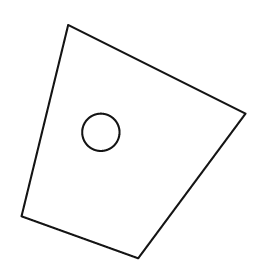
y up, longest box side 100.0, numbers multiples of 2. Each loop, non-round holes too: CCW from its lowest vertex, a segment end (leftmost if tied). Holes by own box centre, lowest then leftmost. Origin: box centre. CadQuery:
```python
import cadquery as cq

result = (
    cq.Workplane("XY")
    .moveTo(2.0, -50.0)
    .lineTo(48.0, 12.0)
    .lineTo(-28.0, 50.0)
    .lineTo(-48.0, -32.0)
    .close()
    .moveTo(-14.0, 4.0)
    .circle(8.0)
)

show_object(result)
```